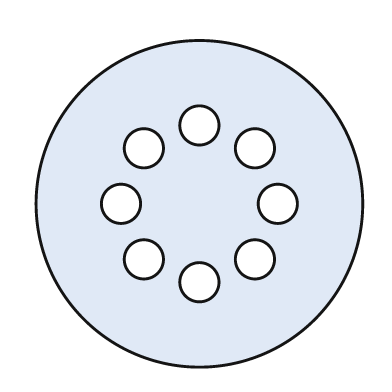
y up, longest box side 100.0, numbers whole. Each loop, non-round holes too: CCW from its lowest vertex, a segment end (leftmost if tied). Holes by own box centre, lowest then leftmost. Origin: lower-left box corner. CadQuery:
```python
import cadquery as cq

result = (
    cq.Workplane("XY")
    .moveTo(50.0, 50.0)
    .circle(50.0)
    .moveTo(50.0, 26.0)
    .circle(6.0)
    .moveTo(33.0, 33.0)
    .circle(6.0)
    .moveTo(67.0, 33.0)
    .circle(6.0)
    .moveTo(26.0, 50.0)
    .circle(6.0)
    .moveTo(74.0, 50.0)
    .circle(6.0)
    .moveTo(33.0, 67.0)
    .circle(6.0)
    .moveTo(67.0, 67.0)
    .circle(6.0)
    .moveTo(50.0, 74.0)
    .circle(6.0)
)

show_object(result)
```